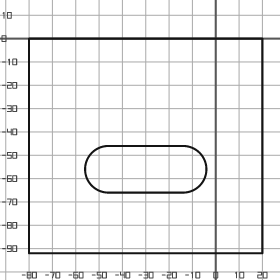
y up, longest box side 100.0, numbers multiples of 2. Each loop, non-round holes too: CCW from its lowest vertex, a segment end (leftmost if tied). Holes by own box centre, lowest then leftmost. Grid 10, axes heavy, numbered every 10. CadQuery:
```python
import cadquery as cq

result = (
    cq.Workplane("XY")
    .moveTo(-80.0, -92.0)
    .lineTo(20.0, -92.0)
    .lineTo(20.0, 0.0)
    .lineTo(-80.0, 0.0)
    .close()
    .moveTo(-46.0, -66.0)
    .lineTo(-14.0, -66.0)
    .threePointArc((-4.0, -56.0), (-14.0, -46.0))
    .lineTo(-46.0, -46.0)
    .threePointArc((-56.0, -56.0), (-46.0, -66.0))
    .close()
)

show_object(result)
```